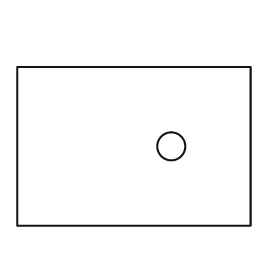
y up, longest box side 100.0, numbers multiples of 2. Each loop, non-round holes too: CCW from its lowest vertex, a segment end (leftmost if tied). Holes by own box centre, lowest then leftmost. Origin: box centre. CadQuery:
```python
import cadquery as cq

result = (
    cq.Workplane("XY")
    .moveTo(-50.0, -34.0)
    .lineTo(50.0, -34.0)
    .lineTo(50.0, 34.0)
    .lineTo(-50.0, 34.0)
    .close()
    .moveTo(16.0, 0.0)
    .circle(6.0)
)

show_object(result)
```